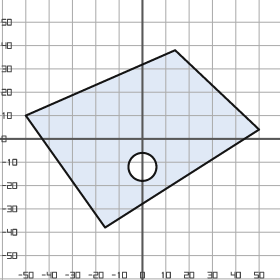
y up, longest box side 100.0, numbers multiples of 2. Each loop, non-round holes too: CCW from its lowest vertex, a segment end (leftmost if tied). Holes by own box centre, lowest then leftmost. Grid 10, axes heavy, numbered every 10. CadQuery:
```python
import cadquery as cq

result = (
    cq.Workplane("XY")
    .moveTo(-16.0, -38.0)
    .lineTo(50.0, 4.0)
    .lineTo(14.0, 38.0)
    .lineTo(-50.0, 10.0)
    .close()
    .moveTo(0.0, -12.0)
    .circle(6.0)
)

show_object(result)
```